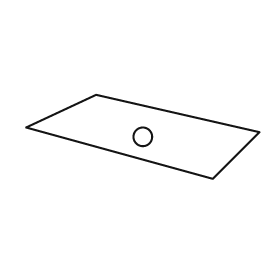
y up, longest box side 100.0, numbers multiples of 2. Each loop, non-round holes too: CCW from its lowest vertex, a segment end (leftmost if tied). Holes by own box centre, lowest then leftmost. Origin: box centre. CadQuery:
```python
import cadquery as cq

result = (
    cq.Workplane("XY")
    .moveTo(30.0, -18.0)
    .lineTo(50.0, 2.0)
    .lineTo(-20.0, 18.0)
    .lineTo(-50.0, 4.0)
    .close()
    .moveTo(0.0, 0.0)
    .circle(4.0)
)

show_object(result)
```